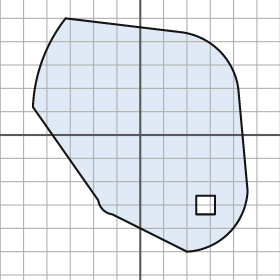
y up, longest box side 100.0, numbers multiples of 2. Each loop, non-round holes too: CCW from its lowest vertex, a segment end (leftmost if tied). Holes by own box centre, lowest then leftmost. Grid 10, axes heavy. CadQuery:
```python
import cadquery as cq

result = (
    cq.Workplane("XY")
    .moveTo(20.0, -50.0)
    .threePointArc((38.0, -42.0), (46.0, -24.0))
    .lineTo(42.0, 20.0)
    .threePointArc((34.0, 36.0), (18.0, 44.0))
    .lineTo(-32.0, 50.0)
    .threePointArc((-42.0, 32.0), (-46.0, 12.0))
    .lineTo(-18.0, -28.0)
    .threePointArc((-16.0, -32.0), (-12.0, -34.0))
    .close()
    .moveTo(24.0, -34.0)
    .lineTo(32.0, -34.0)
    .lineTo(32.0, -26.0)
    .lineTo(24.0, -26.0)
    .close()
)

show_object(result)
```